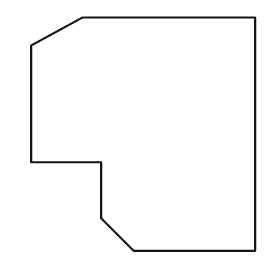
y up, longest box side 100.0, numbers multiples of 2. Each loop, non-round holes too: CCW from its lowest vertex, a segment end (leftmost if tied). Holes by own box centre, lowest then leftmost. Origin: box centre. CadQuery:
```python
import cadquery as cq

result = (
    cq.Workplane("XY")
    .moveTo(-4.0, -50.0)
    .lineTo(48.0, -50.0)
    .lineTo(48.0, 50.0)
    .lineTo(-26.0, 50.0)
    .lineTo(-48.0, 38.0)
    .lineTo(-48.0, -12.0)
    .lineTo(-18.0, -12.0)
    .lineTo(-18.0, -36.0)
    .close()
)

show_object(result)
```